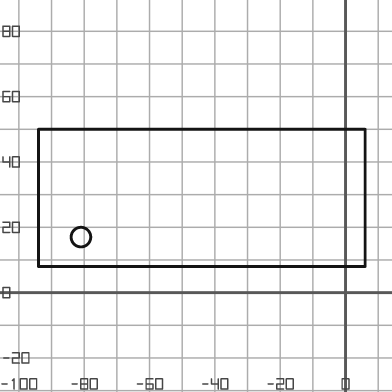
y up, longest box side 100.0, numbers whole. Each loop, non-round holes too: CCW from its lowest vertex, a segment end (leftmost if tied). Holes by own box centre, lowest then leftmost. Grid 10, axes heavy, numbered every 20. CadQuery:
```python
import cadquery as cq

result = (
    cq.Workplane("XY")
    .moveTo(-94.0, 8.0)
    .lineTo(6.0, 8.0)
    .lineTo(6.0, 50.0)
    .lineTo(-94.0, 50.0)
    .close()
    .moveTo(-81.0, 17.0)
    .circle(3.0)
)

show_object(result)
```